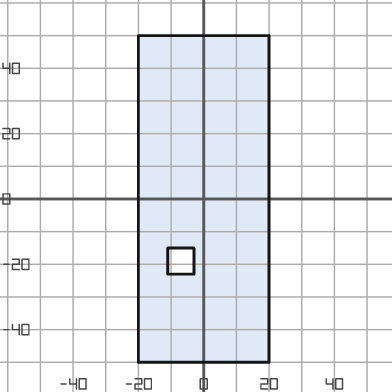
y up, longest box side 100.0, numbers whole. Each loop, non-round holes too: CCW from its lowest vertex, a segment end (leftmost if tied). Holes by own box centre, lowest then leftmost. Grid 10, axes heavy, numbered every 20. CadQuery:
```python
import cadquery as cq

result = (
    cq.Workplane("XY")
    .moveTo(-20.0, -50.0)
    .lineTo(20.0, -50.0)
    .lineTo(20.0, 50.0)
    .lineTo(-20.0, 50.0)
    .close()
    .moveTo(-11.0, -23.0)
    .lineTo(-3.0, -23.0)
    .lineTo(-3.0, -15.0)
    .lineTo(-11.0, -15.0)
    .close()
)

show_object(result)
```